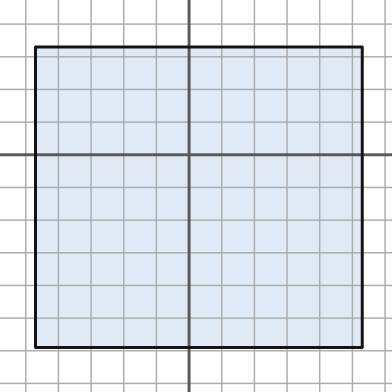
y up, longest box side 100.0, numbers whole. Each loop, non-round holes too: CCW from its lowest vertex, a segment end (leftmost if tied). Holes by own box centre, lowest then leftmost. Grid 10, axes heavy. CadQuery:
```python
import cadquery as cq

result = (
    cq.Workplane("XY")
    .moveTo(-47.0, -59.0)
    .lineTo(53.0, -59.0)
    .lineTo(53.0, 33.0)
    .lineTo(-47.0, 33.0)
    .close()
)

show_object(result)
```